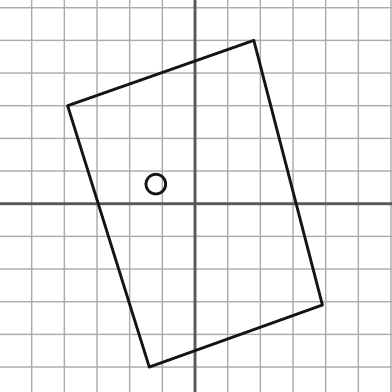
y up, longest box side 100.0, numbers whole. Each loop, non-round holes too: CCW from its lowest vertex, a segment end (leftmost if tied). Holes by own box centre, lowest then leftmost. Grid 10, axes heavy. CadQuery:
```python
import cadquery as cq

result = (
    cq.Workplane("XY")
    .moveTo(-14.0, -50.0)
    .lineTo(39.0, -31.0)
    .lineTo(18.0, 50.0)
    .lineTo(-39.0, 30.0)
    .close()
    .moveTo(-12.0, 6.0)
    .circle(3.0)
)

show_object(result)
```